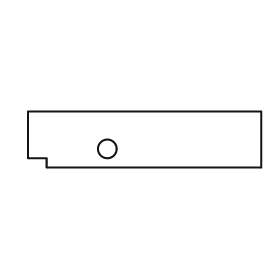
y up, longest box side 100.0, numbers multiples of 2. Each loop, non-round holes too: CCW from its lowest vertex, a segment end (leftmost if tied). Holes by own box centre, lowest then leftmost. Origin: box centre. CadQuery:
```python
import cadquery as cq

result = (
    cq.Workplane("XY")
    .moveTo(-42.0, -12.0)
    .lineTo(50.0, -12.0)
    .lineTo(50.0, 12.0)
    .lineTo(-50.0, 12.0)
    .lineTo(-50.0, -8.0)
    .lineTo(-42.0, -8.0)
    .close()
    .moveTo(-16.0, -4.0)
    .circle(4.0)
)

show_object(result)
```